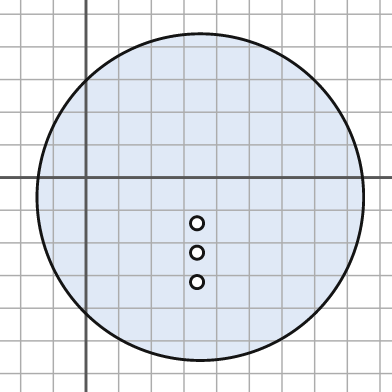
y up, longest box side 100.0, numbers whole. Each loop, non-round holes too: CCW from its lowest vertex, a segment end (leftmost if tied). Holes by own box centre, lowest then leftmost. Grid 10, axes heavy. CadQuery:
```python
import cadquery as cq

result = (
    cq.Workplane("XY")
    .moveTo(35.0, -6.0)
    .circle(50.0)
    .moveTo(34.0, -32.0)
    .circle(2.0)
    .moveTo(34.0, -23.0)
    .circle(2.0)
    .moveTo(34.0, -14.0)
    .circle(2.0)
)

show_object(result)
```